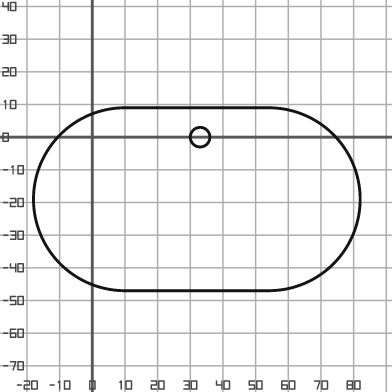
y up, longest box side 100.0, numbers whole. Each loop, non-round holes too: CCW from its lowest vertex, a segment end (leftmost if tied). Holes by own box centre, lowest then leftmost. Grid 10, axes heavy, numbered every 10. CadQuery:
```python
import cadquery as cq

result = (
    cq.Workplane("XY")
    .moveTo(10.0, -47.0)
    .lineTo(54.0, -47.0)
    .threePointArc((82.0, -19.0), (54.0, 9.0))
    .lineTo(10.0, 9.0)
    .threePointArc((-18.0, -19.0), (10.0, -47.0))
    .close()
    .moveTo(33.0, 0.0)
    .circle(3.0)
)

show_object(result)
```